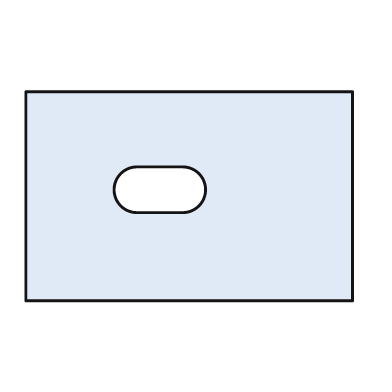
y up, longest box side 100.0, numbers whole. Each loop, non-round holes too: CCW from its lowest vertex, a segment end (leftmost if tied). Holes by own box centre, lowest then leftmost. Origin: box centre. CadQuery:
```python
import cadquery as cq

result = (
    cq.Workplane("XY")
    .moveTo(-50.0, -32.0)
    .lineTo(50.0, -32.0)
    .lineTo(50.0, 32.0)
    .lineTo(-50.0, 32.0)
    .close()
    .moveTo(-16.0, -5.0)
    .lineTo(-2.0, -5.0)
    .threePointArc((5.0, 2.0), (-2.0, 9.0))
    .lineTo(-16.0, 9.0)
    .threePointArc((-23.0, 2.0), (-16.0, -5.0))
    .close()
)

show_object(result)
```